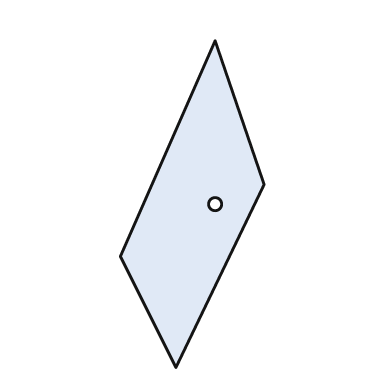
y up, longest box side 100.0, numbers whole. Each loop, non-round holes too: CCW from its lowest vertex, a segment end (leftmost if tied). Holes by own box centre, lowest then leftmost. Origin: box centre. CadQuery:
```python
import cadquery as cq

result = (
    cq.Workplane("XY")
    .moveTo(-5.0, -50.0)
    .lineTo(22.0, 6.0)
    .lineTo(7.0, 50.0)
    .lineTo(-22.0, -16.0)
    .close()
    .moveTo(7.0, 0.0)
    .circle(2.0)
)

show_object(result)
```